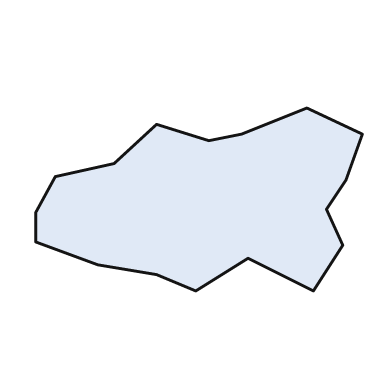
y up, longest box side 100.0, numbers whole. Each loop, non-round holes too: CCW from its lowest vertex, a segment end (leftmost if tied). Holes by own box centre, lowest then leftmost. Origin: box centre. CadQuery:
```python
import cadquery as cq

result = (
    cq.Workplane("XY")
    .moveTo(-1.0, -28.0)
    .lineTo(15.0, -18.0)
    .lineTo(35.0, -28.0)
    .lineTo(44.0, -14.0)
    .lineTo(39.0, -3.0)
    .lineTo(45.0, 6.0)
    .lineTo(50.0, 20.0)
    .lineTo(33.0, 28.0)
    .lineTo(13.0, 20.0)
    .lineTo(3.0, 18.0)
    .lineTo(-13.0, 23.0)
    .lineTo(-26.0, 11.0)
    .lineTo(-44.0, 7.0)
    .lineTo(-50.0, -4.0)
    .lineTo(-50.0, -13.0)
    .lineTo(-31.0, -20.0)
    .lineTo(-13.0, -23.0)
    .close()
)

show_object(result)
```